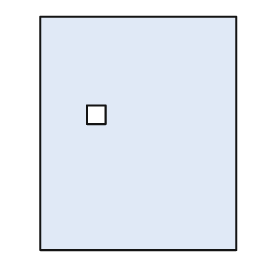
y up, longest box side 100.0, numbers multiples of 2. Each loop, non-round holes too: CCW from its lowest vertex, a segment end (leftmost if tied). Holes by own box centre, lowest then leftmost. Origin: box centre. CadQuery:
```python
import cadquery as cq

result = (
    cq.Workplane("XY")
    .moveTo(-42.0, -50.0)
    .lineTo(42.0, -50.0)
    .lineTo(42.0, 50.0)
    .lineTo(-42.0, 50.0)
    .close()
    .moveTo(-22.0, 4.0)
    .lineTo(-14.0, 4.0)
    .lineTo(-14.0, 12.0)
    .lineTo(-22.0, 12.0)
    .close()
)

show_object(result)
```